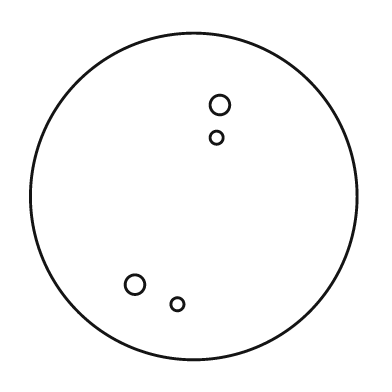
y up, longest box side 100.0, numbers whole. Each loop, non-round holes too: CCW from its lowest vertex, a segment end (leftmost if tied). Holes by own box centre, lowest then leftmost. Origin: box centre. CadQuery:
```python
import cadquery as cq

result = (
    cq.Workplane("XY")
    .moveTo(0.0, 0.0)
    .circle(50.0)
    .moveTo(-5.0, -33.0)
    .circle(2.0)
    .moveTo(-18.0, -27.0)
    .circle(3.0)
    .moveTo(7.0, 18.0)
    .circle(2.0)
    .moveTo(8.0, 28.0)
    .circle(3.0)
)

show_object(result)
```